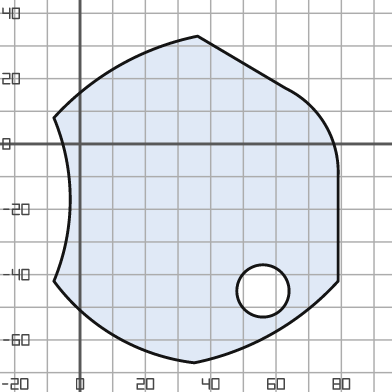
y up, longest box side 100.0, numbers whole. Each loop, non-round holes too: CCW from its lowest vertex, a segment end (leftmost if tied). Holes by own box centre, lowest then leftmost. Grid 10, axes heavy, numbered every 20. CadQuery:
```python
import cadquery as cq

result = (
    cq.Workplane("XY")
    .moveTo(35.0, -67.0)
    .threePointArc((59.0, -58.0), (79.0, -42.0))
    .lineTo(79.0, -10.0)
    .threePointArc((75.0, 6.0), (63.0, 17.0))
    .lineTo(36.0, 33.0)
    .threePointArc((12.0, 24.0), (-8.0, 8.0))
    .threePointArc((-3.0, -17.0), (-8.0, -42.0))
    .threePointArc((11.0, -59.0), (35.0, -67.0))
    .close()
    .moveTo(56.0, -45.0)
    .circle(8.0)
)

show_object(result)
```